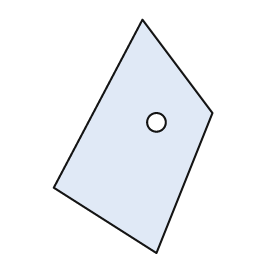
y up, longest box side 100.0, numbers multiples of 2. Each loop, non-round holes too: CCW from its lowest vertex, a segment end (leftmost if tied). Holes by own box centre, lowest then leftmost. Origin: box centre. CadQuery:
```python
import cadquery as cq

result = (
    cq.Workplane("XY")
    .moveTo(10.0, -50.0)
    .lineTo(34.0, 10.0)
    .lineTo(4.0, 50.0)
    .lineTo(-34.0, -22.0)
    .close()
    .moveTo(10.0, 6.0)
    .circle(4.0)
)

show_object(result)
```